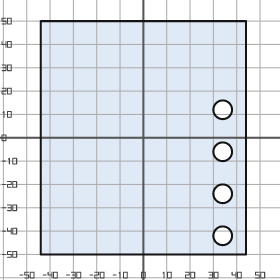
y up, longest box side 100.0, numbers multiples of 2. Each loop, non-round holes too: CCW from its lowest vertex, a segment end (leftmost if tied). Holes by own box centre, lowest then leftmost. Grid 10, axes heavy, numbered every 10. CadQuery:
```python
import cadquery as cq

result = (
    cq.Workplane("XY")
    .moveTo(-44.0, -50.0)
    .lineTo(44.0, -50.0)
    .lineTo(44.0, 50.0)
    .lineTo(-44.0, 50.0)
    .close()
    .moveTo(34.0, -42.0)
    .circle(4.0)
    .moveTo(34.0, -24.0)
    .circle(4.0)
    .moveTo(34.0, -6.0)
    .circle(4.0)
    .moveTo(34.0, 12.0)
    .circle(4.0)
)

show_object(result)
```